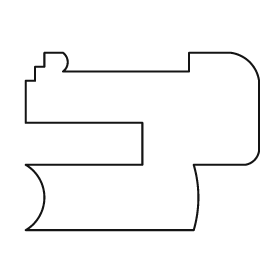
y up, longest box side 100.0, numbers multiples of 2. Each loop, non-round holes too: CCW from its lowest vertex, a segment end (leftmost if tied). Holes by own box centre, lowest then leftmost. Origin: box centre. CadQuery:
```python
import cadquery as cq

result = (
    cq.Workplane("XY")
    .moveTo(-50.0, -38.0)
    .lineTo(22.0, -38.0)
    .threePointArc((24.0, -24.0), (22.0, -10.0))
    .lineTo(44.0, -10.0)
    .threePointArc((48.0, -8.0), (50.0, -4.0))
    .lineTo(50.0, 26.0)
    .threePointArc((46.0, 34.0), (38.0, 38.0))
    .lineTo(20.0, 38.0)
    .lineTo(20.0, 30.0)
    .lineTo(-34.0, 30.0)
    .threePointArc((-32.0, 34.0), (-34.0, 38.0))
    .lineTo(-42.0, 38.0)
    .lineTo(-42.0, 32.0)
    .lineTo(-46.0, 32.0)
    .lineTo(-46.0, 26.0)
    .lineTo(-50.0, 26.0)
    .lineTo(-50.0, 8.0)
    .lineTo(0.0, 8.0)
    .lineTo(0.0, -10.0)
    .lineTo(-50.0, -10.0)
    .threePointArc((-42.0, -24.0), (-50.0, -38.0))
    .close()
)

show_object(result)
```